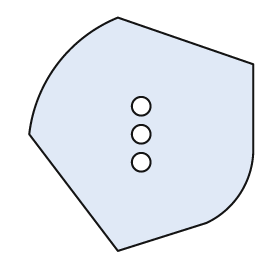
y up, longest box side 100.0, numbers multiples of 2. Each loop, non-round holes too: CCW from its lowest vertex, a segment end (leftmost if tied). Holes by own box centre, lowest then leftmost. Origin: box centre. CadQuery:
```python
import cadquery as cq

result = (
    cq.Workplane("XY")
    .moveTo(-10.0, -50.0)
    .lineTo(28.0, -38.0)
    .threePointArc((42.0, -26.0), (48.0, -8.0))
    .lineTo(48.0, 30.0)
    .lineTo(-10.0, 50.0)
    .threePointArc((-36.0, 30.0), (-48.0, 0.0))
    .close()
    .moveTo(0.0, -12.0)
    .circle(4.0)
    .moveTo(0.0, 0.0)
    .circle(4.0)
    .moveTo(0.0, 12.0)
    .circle(4.0)
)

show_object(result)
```